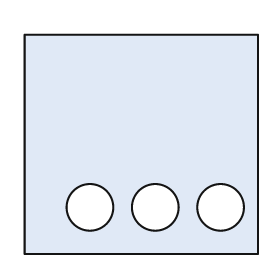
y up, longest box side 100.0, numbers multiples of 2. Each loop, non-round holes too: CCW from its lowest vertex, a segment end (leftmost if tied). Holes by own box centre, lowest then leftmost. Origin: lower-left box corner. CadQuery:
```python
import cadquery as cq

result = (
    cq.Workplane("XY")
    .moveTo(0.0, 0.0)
    .lineTo(100.0, 0.0)
    .lineTo(100.0, 94.0)
    .lineTo(0.0, 94.0)
    .close()
    .moveTo(28.0, 20.0)
    .circle(10.0)
    .moveTo(56.0, 20.0)
    .circle(10.0)
    .moveTo(84.0, 20.0)
    .circle(10.0)
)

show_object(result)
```